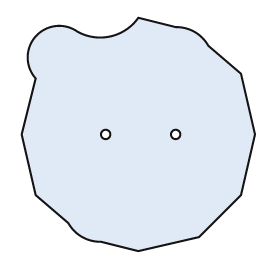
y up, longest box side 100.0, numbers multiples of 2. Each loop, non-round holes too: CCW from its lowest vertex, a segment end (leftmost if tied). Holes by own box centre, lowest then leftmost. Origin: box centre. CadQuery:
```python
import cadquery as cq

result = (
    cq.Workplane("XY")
    .moveTo(0.0, -50.0)
    .lineTo(26.0, -44.0)
    .lineTo(44.0, -26.0)
    .lineTo(50.0, 0.0)
    .lineTo(44.0, 26.0)
    .lineTo(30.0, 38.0)
    .threePointArc((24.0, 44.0), (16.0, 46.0))
    .lineTo(0.0, 50.0)
    .threePointArc((-12.0, 42.0), (-26.0, 44.0))
    .threePointArc((-44.0, 42.0), (-44.0, 24.0))
    .lineTo(-50.0, 0.0)
    .lineTo(-44.0, -26.0)
    .lineTo(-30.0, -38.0)
    .threePointArc((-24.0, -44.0), (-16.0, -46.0))
    .close()
    .moveTo(-14.0, 0.0)
    .circle(2.0)
    .moveTo(16.0, 0.0)
    .circle(2.0)
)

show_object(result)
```